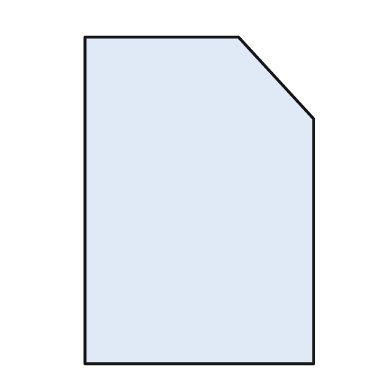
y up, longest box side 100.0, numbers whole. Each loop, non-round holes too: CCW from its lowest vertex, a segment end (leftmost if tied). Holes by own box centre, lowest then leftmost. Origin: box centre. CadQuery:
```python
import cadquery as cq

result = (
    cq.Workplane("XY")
    .moveTo(-35.0, -50.0)
    .lineTo(35.0, -50.0)
    .lineTo(35.0, 25.0)
    .lineTo(12.0, 50.0)
    .lineTo(-35.0, 50.0)
    .close()
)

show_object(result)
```